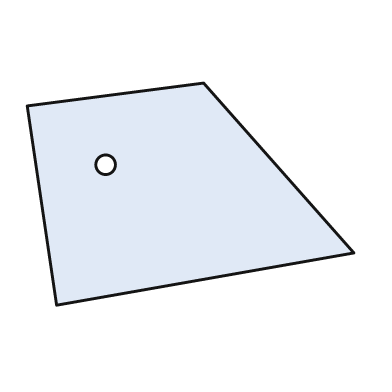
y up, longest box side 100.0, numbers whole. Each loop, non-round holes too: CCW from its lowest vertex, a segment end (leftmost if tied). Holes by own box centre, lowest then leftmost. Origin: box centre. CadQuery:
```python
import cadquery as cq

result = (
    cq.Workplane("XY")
    .moveTo(-41.0, -34.0)
    .lineTo(50.0, -18.0)
    .lineTo(4.0, 34.0)
    .lineTo(-50.0, 27.0)
    .close()
    .moveTo(-26.0, 9.0)
    .circle(3.0)
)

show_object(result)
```